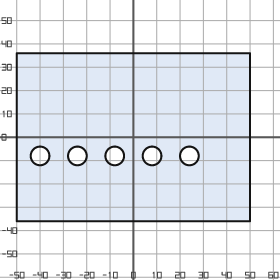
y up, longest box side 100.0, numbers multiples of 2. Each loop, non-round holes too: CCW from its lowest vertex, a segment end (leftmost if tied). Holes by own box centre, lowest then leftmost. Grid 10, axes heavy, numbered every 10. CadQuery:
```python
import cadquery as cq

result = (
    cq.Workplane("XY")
    .moveTo(-50.0, -36.0)
    .lineTo(50.0, -36.0)
    .lineTo(50.0, 36.0)
    .lineTo(-50.0, 36.0)
    .close()
    .moveTo(-40.0, -8.0)
    .circle(4.0)
    .moveTo(-24.0, -8.0)
    .circle(4.0)
    .moveTo(-8.0, -8.0)
    .circle(4.0)
    .moveTo(8.0, -8.0)
    .circle(4.0)
    .moveTo(24.0, -8.0)
    .circle(4.0)
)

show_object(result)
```